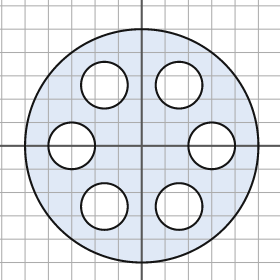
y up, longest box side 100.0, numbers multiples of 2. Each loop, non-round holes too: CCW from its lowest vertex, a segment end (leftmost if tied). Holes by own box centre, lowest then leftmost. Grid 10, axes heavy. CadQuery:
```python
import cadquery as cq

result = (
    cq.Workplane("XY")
    .moveTo(0.0, 0.0)
    .circle(50.0)
    .moveTo(-16.0, -26.0)
    .circle(10.0)
    .moveTo(16.0, -26.0)
    .circle(10.0)
    .moveTo(-30.0, 0.0)
    .circle(10.0)
    .moveTo(30.0, 0.0)
    .circle(10.0)
    .moveTo(-16.0, 26.0)
    .circle(10.0)
    .moveTo(16.0, 26.0)
    .circle(10.0)
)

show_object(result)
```